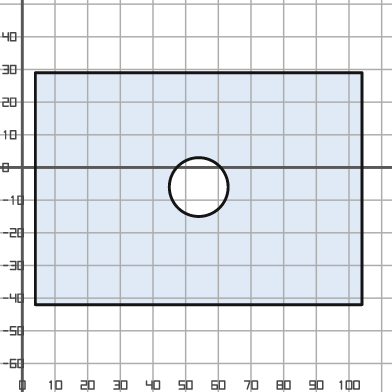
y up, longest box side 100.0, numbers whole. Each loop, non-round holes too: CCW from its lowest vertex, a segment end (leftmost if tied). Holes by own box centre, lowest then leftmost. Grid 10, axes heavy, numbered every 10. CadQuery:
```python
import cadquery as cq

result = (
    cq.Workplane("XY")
    .moveTo(4.0, -42.0)
    .lineTo(104.0, -42.0)
    .lineTo(104.0, 29.0)
    .lineTo(4.0, 29.0)
    .close()
    .moveTo(54.0, -6.0)
    .circle(9.0)
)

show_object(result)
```